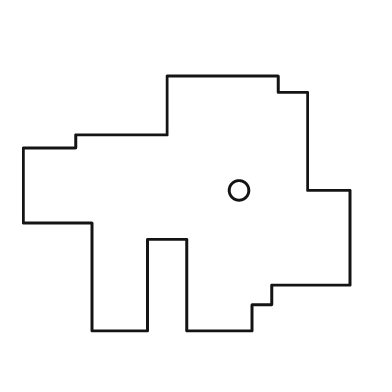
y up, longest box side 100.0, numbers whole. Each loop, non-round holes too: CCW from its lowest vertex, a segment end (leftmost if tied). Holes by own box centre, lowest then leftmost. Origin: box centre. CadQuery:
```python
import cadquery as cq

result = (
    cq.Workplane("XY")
    .moveTo(-29.0, -39.0)
    .lineTo(-12.0, -39.0)
    .lineTo(-12.0, -11.0)
    .lineTo(0.0, -11.0)
    .lineTo(0.0, -39.0)
    .lineTo(20.0, -39.0)
    .lineTo(20.0, -31.0)
    .lineTo(26.0, -31.0)
    .lineTo(26.0, -25.0)
    .lineTo(50.0, -25.0)
    .lineTo(50.0, 4.0)
    .lineTo(37.0, 4.0)
    .lineTo(37.0, 34.0)
    .lineTo(28.0, 34.0)
    .lineTo(28.0, 39.0)
    .lineTo(-6.0, 39.0)
    .lineTo(-6.0, 21.0)
    .lineTo(-34.0, 21.0)
    .lineTo(-34.0, 17.0)
    .lineTo(-50.0, 17.0)
    .lineTo(-50.0, -6.0)
    .lineTo(-29.0, -6.0)
    .close()
    .moveTo(16.0, 4.0)
    .circle(3.0)
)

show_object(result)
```